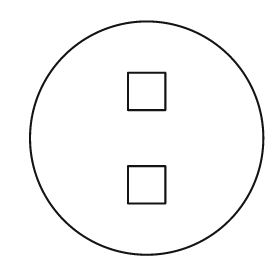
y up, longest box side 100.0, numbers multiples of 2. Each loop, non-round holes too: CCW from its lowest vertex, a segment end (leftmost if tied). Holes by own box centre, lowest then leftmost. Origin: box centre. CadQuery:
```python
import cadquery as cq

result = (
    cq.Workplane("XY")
    .moveTo(0.0, 0.0)
    .circle(50.0)
    .moveTo(-8.0, -28.0)
    .lineTo(8.0, -28.0)
    .lineTo(8.0, -12.0)
    .lineTo(-8.0, -12.0)
    .close()
    .moveTo(-8.0, 12.0)
    .lineTo(8.0, 12.0)
    .lineTo(8.0, 28.0)
    .lineTo(-8.0, 28.0)
    .close()
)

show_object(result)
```